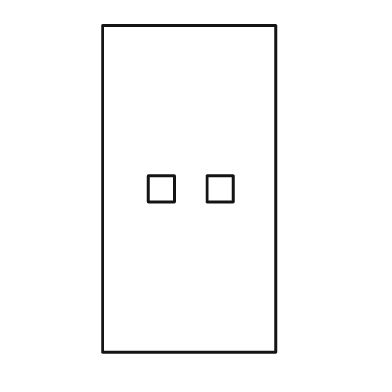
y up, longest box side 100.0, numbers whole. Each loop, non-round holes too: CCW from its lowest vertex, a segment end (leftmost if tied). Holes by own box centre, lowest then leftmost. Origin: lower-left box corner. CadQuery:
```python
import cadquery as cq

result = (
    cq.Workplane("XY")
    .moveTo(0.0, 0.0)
    .lineTo(53.0, 0.0)
    .lineTo(53.0, 100.0)
    .lineTo(0.0, 100.0)
    .close()
    .moveTo(14.0, 46.0)
    .lineTo(22.0, 46.0)
    .lineTo(22.0, 54.0)
    .lineTo(14.0, 54.0)
    .close()
    .moveTo(32.0, 46.0)
    .lineTo(40.0, 46.0)
    .lineTo(40.0, 54.0)
    .lineTo(32.0, 54.0)
    .close()
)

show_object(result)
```